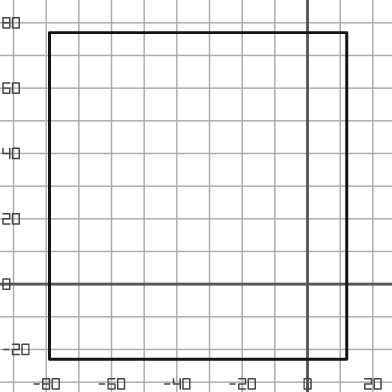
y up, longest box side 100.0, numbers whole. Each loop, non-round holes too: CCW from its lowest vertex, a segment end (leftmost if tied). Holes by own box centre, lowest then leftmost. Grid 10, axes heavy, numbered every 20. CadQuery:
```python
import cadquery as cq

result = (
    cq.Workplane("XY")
    .moveTo(-79.0, -23.0)
    .lineTo(12.0, -23.0)
    .lineTo(12.0, 77.0)
    .lineTo(-79.0, 77.0)
    .close()
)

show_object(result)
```